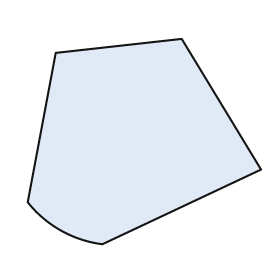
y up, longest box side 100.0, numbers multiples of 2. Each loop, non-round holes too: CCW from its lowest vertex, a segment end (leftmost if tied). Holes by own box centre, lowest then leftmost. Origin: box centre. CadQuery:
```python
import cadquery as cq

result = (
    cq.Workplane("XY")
    .moveTo(-18.0, -44.0)
    .lineTo(50.0, -12.0)
    .lineTo(16.0, 44.0)
    .lineTo(-38.0, 38.0)
    .lineTo(-50.0, -26.0)
    .threePointArc((-36.0, -38.0), (-18.0, -44.0))
    .close()
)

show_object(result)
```